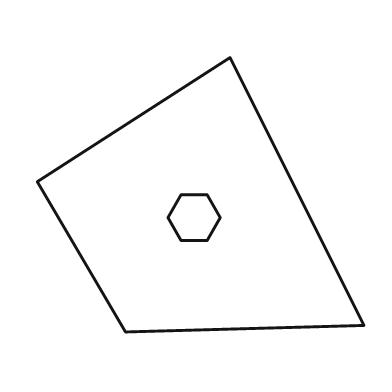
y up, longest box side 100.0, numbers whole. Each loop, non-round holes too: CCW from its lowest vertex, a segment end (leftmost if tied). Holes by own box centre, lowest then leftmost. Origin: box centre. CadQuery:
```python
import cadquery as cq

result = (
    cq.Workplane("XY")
    .moveTo(-23.0, -42.0)
    .lineTo(50.0, -40.0)
    .lineTo(9.0, 42.0)
    .lineTo(-50.0, 4.0)
    .close()
    .moveTo(-6.0, -14.0)
    .lineTo(2.0, -14.0)
    .lineTo(6.0, -7.0)
    .lineTo(2.0, 0.0)
    .lineTo(-6.0, 0.0)
    .lineTo(-10.0, -7.0)
    .close()
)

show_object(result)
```